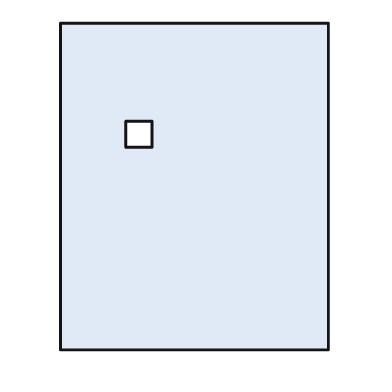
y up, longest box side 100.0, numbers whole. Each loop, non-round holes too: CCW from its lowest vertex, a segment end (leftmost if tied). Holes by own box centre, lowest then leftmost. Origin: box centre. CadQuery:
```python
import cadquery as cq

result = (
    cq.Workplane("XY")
    .moveTo(-41.0, -50.0)
    .lineTo(41.0, -50.0)
    .lineTo(41.0, 50.0)
    .lineTo(-41.0, 50.0)
    .close()
    .moveTo(-21.0, 12.0)
    .lineTo(-13.0, 12.0)
    .lineTo(-13.0, 20.0)
    .lineTo(-21.0, 20.0)
    .close()
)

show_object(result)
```